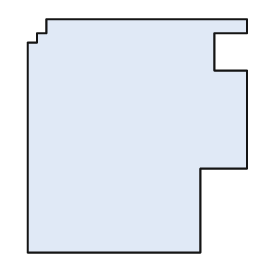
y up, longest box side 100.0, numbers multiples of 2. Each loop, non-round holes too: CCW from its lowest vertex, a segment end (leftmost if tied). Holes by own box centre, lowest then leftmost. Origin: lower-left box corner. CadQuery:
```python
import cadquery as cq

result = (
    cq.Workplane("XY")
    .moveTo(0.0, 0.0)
    .lineTo(74.0, 0.0)
    .lineTo(74.0, 36.0)
    .lineTo(94.0, 36.0)
    .lineTo(94.0, 78.0)
    .lineTo(80.0, 78.0)
    .lineTo(80.0, 94.0)
    .lineTo(94.0, 94.0)
    .lineTo(94.0, 100.0)
    .lineTo(8.0, 100.0)
    .lineTo(8.0, 94.0)
    .lineTo(4.0, 94.0)
    .lineTo(4.0, 90.0)
    .lineTo(0.0, 90.0)
    .close()
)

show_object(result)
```